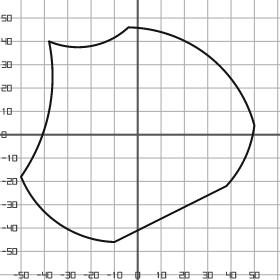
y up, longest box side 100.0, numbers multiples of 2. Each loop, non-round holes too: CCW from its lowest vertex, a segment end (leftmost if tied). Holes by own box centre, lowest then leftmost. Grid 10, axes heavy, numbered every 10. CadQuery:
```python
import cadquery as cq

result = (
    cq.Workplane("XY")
    .moveTo(-10.0, -46.0)
    .lineTo(38.0, -22.0)
    .threePointArc((46.0, -10.0), (50.0, 4.0))
    .threePointArc((30.0, 34.0), (-4.0, 46.0))
    .threePointArc((-20.0, 38.0), (-38.0, 40.0))
    .threePointArc((-38.0, 10.0), (-50.0, -18.0))
    .threePointArc((-34.0, -38.0), (-10.0, -46.0))
    .close()
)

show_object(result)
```